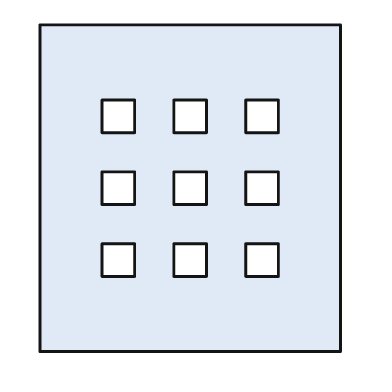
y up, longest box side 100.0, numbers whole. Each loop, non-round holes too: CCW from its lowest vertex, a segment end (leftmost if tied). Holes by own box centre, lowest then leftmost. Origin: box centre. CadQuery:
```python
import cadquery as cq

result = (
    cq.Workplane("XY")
    .moveTo(-46.0, -50.0)
    .lineTo(46.0, -50.0)
    .lineTo(46.0, 50.0)
    .lineTo(-46.0, 50.0)
    .close()
    .moveTo(-27.0, -27.0)
    .lineTo(-17.0, -27.0)
    .lineTo(-17.0, -17.0)
    .lineTo(-27.0, -17.0)
    .close()
    .moveTo(-5.0, -27.0)
    .lineTo(5.0, -27.0)
    .lineTo(5.0, -17.0)
    .lineTo(-5.0, -17.0)
    .close()
    .moveTo(17.0, -27.0)
    .lineTo(27.0, -27.0)
    .lineTo(27.0, -17.0)
    .lineTo(17.0, -17.0)
    .close()
    .moveTo(-27.0, -5.0)
    .lineTo(-17.0, -5.0)
    .lineTo(-17.0, 5.0)
    .lineTo(-27.0, 5.0)
    .close()
    .moveTo(-5.0, -5.0)
    .lineTo(5.0, -5.0)
    .lineTo(5.0, 5.0)
    .lineTo(-5.0, 5.0)
    .close()
    .moveTo(17.0, -5.0)
    .lineTo(27.0, -5.0)
    .lineTo(27.0, 5.0)
    .lineTo(17.0, 5.0)
    .close()
    .moveTo(-27.0, 17.0)
    .lineTo(-17.0, 17.0)
    .lineTo(-17.0, 27.0)
    .lineTo(-27.0, 27.0)
    .close()
    .moveTo(-5.0, 17.0)
    .lineTo(5.0, 17.0)
    .lineTo(5.0, 27.0)
    .lineTo(-5.0, 27.0)
    .close()
    .moveTo(17.0, 17.0)
    .lineTo(27.0, 17.0)
    .lineTo(27.0, 27.0)
    .lineTo(17.0, 27.0)
    .close()
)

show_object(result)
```